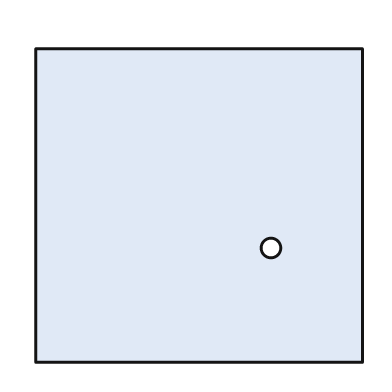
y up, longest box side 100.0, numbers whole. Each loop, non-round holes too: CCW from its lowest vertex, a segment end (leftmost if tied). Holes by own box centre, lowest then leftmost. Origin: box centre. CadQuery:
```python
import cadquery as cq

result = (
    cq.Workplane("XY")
    .moveTo(-50.0, -48.0)
    .lineTo(50.0, -48.0)
    .lineTo(50.0, 48.0)
    .lineTo(-50.0, 48.0)
    .close()
    .moveTo(22.0, -13.0)
    .circle(3.0)
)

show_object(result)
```